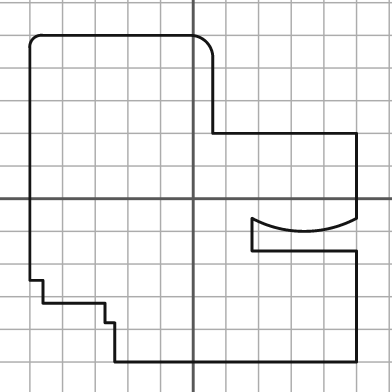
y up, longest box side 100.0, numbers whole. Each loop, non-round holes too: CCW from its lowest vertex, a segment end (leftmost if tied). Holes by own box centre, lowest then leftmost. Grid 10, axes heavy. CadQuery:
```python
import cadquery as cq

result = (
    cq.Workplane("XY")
    .moveTo(-24.0, -50.0)
    .lineTo(50.0, -50.0)
    .lineTo(50.0, -16.0)
    .lineTo(18.0, -16.0)
    .lineTo(18.0, -6.0)
    .threePointArc((34.0, -10.0), (50.0, -6.0))
    .lineTo(50.0, 20.0)
    .lineTo(6.0, 20.0)
    .lineTo(6.0, 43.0)
    .threePointArc((4.0, 48.0), (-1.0, 50.0))
    .lineTo(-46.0, 50.0)
    .threePointArc((-49.0, 49.0), (-50.0, 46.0))
    .lineTo(-50.0, -25.0)
    .lineTo(-46.0, -25.0)
    .lineTo(-46.0, -32.0)
    .lineTo(-27.0, -32.0)
    .lineTo(-27.0, -38.0)
    .lineTo(-24.0, -38.0)
    .close()
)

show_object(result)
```